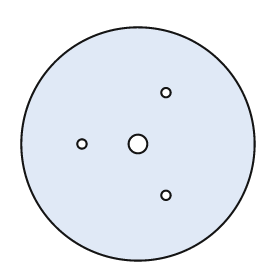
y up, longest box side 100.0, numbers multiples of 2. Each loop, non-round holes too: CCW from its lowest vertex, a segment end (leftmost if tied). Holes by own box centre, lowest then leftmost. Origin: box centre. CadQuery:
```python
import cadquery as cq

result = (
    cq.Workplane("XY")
    .moveTo(0.0, 0.0)
    .circle(50.0)
    .moveTo(12.0, -22.0)
    .circle(2.0)
    .moveTo(-24.0, 0.0)
    .circle(2.0)
    .moveTo(0.0, 0.0)
    .circle(4.0)
    .moveTo(12.0, 22.0)
    .circle(2.0)
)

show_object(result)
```